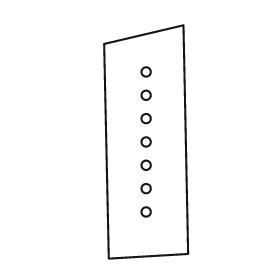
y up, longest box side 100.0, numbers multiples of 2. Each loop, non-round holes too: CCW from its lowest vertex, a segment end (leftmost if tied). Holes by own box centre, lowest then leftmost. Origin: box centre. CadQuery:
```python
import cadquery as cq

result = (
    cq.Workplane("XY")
    .moveTo(-16.0, -50.0)
    .lineTo(18.0, -48.0)
    .lineTo(16.0, 50.0)
    .lineTo(-18.0, 42.0)
    .close()
    .moveTo(0.0, -30.0)
    .circle(2.0)
    .moveTo(0.0, -20.0)
    .circle(2.0)
    .moveTo(0.0, -10.0)
    .circle(2.0)
    .moveTo(0.0, 0.0)
    .circle(2.0)
    .moveTo(0.0, 10.0)
    .circle(2.0)
    .moveTo(0.0, 20.0)
    .circle(2.0)
    .moveTo(0.0, 30.0)
    .circle(2.0)
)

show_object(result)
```